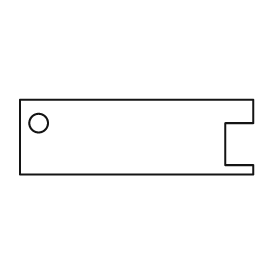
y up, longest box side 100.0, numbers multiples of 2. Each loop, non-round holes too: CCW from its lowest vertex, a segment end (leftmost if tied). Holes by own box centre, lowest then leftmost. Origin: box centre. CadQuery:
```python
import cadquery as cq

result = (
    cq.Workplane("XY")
    .moveTo(-50.0, -16.0)
    .lineTo(50.0, -16.0)
    .lineTo(50.0, -12.0)
    .lineTo(38.0, -12.0)
    .lineTo(38.0, 6.0)
    .lineTo(50.0, 6.0)
    .lineTo(50.0, 16.0)
    .lineTo(-50.0, 16.0)
    .close()
    .moveTo(-42.0, 6.0)
    .circle(4.0)
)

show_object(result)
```